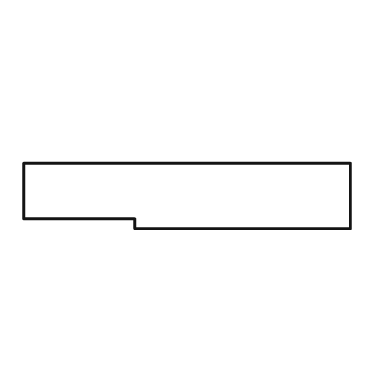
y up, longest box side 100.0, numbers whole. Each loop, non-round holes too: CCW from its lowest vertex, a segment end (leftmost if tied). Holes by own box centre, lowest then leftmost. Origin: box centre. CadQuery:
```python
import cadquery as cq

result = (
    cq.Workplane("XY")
    .moveTo(-16.0, -10.0)
    .lineTo(50.0, -10.0)
    .lineTo(50.0, 10.0)
    .lineTo(-50.0, 10.0)
    .lineTo(-50.0, -7.0)
    .lineTo(-16.0, -7.0)
    .close()
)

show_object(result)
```